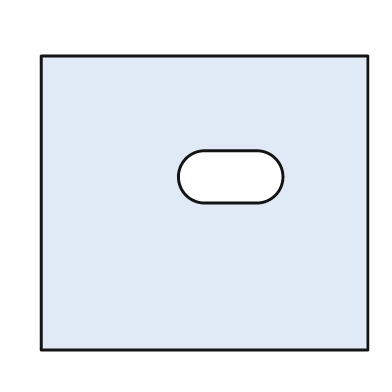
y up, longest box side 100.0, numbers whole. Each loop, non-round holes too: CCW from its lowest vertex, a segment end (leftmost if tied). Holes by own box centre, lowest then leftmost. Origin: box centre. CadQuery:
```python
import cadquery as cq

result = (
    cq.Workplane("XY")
    .moveTo(-50.0, -45.0)
    .lineTo(50.0, -45.0)
    .lineTo(50.0, 45.0)
    .lineTo(-50.0, 45.0)
    .close()
    .moveTo(0.0, 0.0)
    .lineTo(16.0, 0.0)
    .threePointArc((24.0, 8.0), (16.0, 16.0))
    .lineTo(0.0, 16.0)
    .threePointArc((-8.0, 8.0), (0.0, 0.0))
    .close()
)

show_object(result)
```